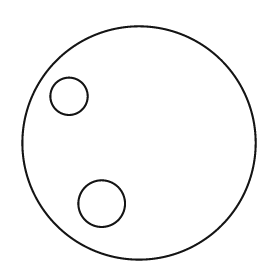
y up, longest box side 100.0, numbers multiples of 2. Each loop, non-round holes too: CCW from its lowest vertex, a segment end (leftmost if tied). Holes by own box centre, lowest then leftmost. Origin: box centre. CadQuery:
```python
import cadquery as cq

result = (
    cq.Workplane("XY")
    .moveTo(0.0, 0.0)
    .circle(50.0)
    .moveTo(-16.0, -26.0)
    .circle(10.0)
    .moveTo(-30.0, 20.0)
    .circle(8.0)
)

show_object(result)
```